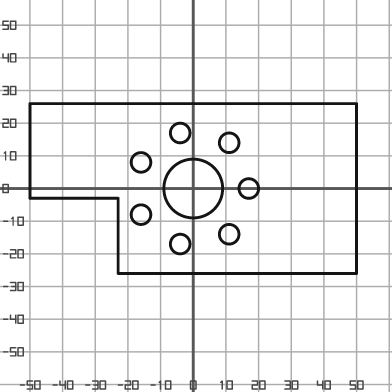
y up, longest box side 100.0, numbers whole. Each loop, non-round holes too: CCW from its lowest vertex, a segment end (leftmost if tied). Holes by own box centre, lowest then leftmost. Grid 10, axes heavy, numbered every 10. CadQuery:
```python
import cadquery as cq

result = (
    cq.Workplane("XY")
    .moveTo(-23.0, -26.0)
    .lineTo(50.0, -26.0)
    .lineTo(50.0, 26.0)
    .lineTo(-50.0, 26.0)
    .lineTo(-50.0, -3.0)
    .lineTo(-23.0, -3.0)
    .close()
    .moveTo(-4.0, -17.0)
    .circle(3.0)
    .moveTo(11.0, -14.0)
    .circle(3.0)
    .moveTo(-16.0, -8.0)
    .circle(3.0)
    .moveTo(0.0, 0.0)
    .circle(9.0)
    .moveTo(17.0, 0.0)
    .circle(3.0)
    .moveTo(-16.0, 8.0)
    .circle(3.0)
    .moveTo(11.0, 14.0)
    .circle(3.0)
    .moveTo(-4.0, 17.0)
    .circle(3.0)
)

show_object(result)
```